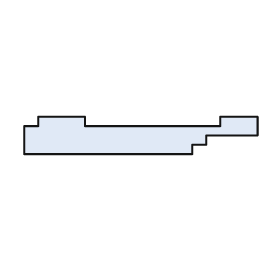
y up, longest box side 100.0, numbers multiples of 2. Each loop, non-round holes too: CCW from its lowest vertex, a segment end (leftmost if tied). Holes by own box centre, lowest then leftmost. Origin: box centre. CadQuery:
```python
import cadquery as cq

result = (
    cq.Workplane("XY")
    .moveTo(-50.0, -8.0)
    .lineTo(22.0, -8.0)
    .lineTo(22.0, -4.0)
    .lineTo(28.0, -4.0)
    .lineTo(28.0, 0.0)
    .lineTo(50.0, 0.0)
    .lineTo(50.0, 8.0)
    .lineTo(34.0, 8.0)
    .lineTo(34.0, 4.0)
    .lineTo(-24.0, 4.0)
    .lineTo(-24.0, 8.0)
    .lineTo(-44.0, 8.0)
    .lineTo(-44.0, 4.0)
    .lineTo(-50.0, 4.0)
    .close()
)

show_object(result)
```